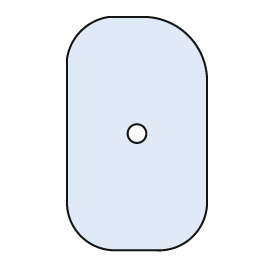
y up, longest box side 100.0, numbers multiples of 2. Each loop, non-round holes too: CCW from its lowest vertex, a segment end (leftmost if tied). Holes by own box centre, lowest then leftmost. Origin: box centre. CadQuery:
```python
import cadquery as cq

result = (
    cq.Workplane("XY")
    .moveTo(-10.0, -50.0)
    .lineTo(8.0, -50.0)
    .threePointArc((24.0, -44.0), (30.0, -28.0))
    .lineTo(30.0, 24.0)
    .threePointArc((22.0, 42.0), (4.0, 50.0))
    .lineTo(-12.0, 50.0)
    .threePointArc((-24.0, 44.0), (-30.0, 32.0))
    .lineTo(-30.0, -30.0)
    .threePointArc((-24.0, -44.0), (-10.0, -50.0))
    .close()
    .moveTo(0.0, 0.0)
    .circle(4.0)
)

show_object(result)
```